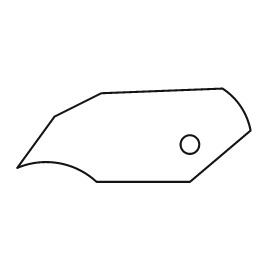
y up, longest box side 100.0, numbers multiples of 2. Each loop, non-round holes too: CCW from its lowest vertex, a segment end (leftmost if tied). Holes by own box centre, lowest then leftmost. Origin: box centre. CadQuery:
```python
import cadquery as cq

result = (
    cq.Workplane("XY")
    .moveTo(-16.0, -20.0)
    .lineTo(24.0, -20.0)
    .lineTo(50.0, 2.0)
    .threePointArc((46.0, 12.0), (38.0, 20.0))
    .lineTo(-14.0, 18.0)
    .lineTo(-34.0, 8.0)
    .lineTo(-50.0, -14.0)
    .threePointArc((-32.0, -12.0), (-16.0, -20.0))
    .close()
    .moveTo(24.0, -4.0)
    .circle(4.0)
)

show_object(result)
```